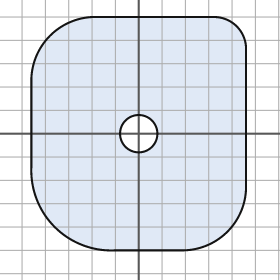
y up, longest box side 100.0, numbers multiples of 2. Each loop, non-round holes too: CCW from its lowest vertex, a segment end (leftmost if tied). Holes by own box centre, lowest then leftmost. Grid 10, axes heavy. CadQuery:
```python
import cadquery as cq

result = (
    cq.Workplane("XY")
    .moveTo(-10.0, -50.0)
    .lineTo(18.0, -50.0)
    .threePointArc((38.0, -42.0), (46.0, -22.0))
    .lineTo(46.0, 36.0)
    .threePointArc((42.0, 46.0), (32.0, 50.0))
    .lineTo(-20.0, 50.0)
    .threePointArc((-38.0, 42.0), (-46.0, 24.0))
    .lineTo(-46.0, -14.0)
    .threePointArc((-36.0, -40.0), (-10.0, -50.0))
    .close()
    .moveTo(0.0, 0.0)
    .circle(8.0)
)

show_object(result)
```